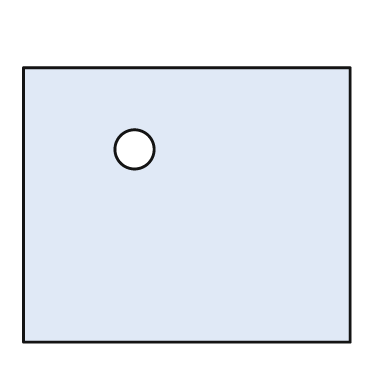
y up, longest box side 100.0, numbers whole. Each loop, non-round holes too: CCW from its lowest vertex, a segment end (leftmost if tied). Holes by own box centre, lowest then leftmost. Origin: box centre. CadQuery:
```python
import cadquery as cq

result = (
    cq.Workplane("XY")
    .moveTo(-50.0, -42.0)
    .lineTo(50.0, -42.0)
    .lineTo(50.0, 42.0)
    .lineTo(-50.0, 42.0)
    .close()
    .moveTo(-16.0, 17.0)
    .circle(6.0)
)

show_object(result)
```